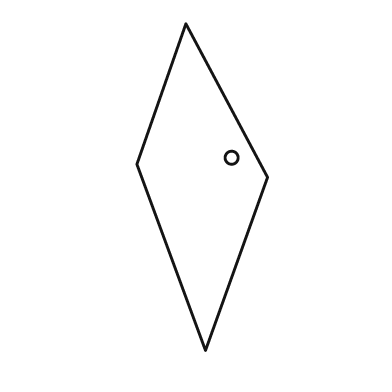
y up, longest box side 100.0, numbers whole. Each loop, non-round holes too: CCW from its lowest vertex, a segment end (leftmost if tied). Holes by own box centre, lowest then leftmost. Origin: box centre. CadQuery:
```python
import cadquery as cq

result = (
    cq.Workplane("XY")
    .moveTo(1.0, -50.0)
    .lineTo(20.0, 3.0)
    .lineTo(-5.0, 50.0)
    .lineTo(-20.0, 7.0)
    .close()
    .moveTo(9.0, 9.0)
    .circle(2.0)
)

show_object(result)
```